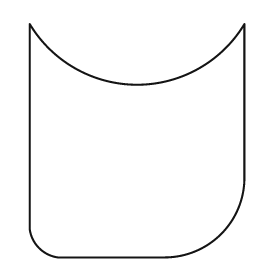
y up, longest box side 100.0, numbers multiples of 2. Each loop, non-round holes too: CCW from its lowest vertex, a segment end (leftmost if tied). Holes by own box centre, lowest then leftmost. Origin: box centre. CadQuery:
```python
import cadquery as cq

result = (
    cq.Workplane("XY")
    .moveTo(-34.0, -50.0)
    .lineTo(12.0, -50.0)
    .threePointArc((36.0, -40.0), (46.0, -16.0))
    .lineTo(46.0, 50.0)
    .threePointArc((0.0, 24.0), (-46.0, 50.0))
    .lineTo(-46.0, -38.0)
    .threePointArc((-42.0, -46.0), (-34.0, -50.0))
    .close()
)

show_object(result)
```